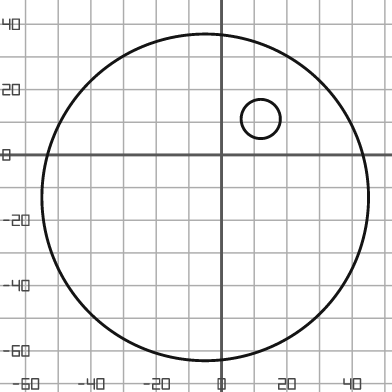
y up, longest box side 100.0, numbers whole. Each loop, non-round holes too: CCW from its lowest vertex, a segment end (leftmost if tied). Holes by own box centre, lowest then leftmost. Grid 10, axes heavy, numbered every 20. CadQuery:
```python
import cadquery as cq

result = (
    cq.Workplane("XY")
    .moveTo(-5.0, -13.0)
    .circle(50.0)
    .moveTo(12.0, 11.0)
    .circle(6.0)
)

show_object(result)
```